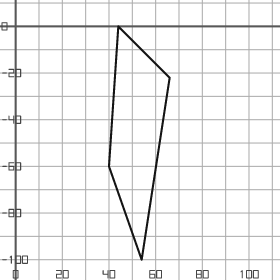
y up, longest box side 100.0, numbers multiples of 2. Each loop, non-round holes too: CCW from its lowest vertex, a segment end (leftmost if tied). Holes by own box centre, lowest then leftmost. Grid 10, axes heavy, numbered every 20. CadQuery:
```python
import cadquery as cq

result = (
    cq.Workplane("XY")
    .moveTo(54.0, -100.0)
    .lineTo(66.0, -22.0)
    .lineTo(44.0, 0.0)
    .lineTo(40.0, -60.0)
    .close()
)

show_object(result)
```